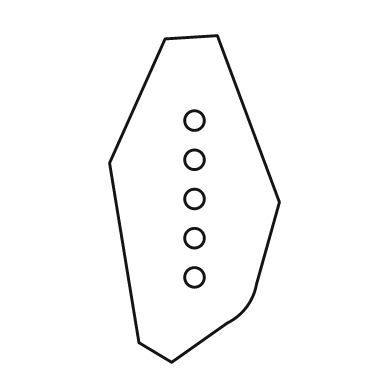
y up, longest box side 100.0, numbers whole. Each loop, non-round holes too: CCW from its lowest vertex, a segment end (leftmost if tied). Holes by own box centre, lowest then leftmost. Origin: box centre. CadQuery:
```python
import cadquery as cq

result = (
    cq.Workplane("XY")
    .moveTo(-7.0, -50.0)
    .lineTo(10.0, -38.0)
    .threePointArc((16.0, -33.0), (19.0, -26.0))
    .lineTo(26.0, -1.0)
    .lineTo(7.0, 50.0)
    .lineTo(-9.0, 49.0)
    .lineTo(-26.0, 11.0)
    .lineTo(-17.0, -44.0)
    .close()
    .moveTo(0.0, -24.0)
    .circle(3.0)
    .moveTo(0.0, -12.0)
    .circle(3.0)
    .moveTo(0.0, 0.0)
    .circle(3.0)
    .moveTo(0.0, 12.0)
    .circle(3.0)
    .moveTo(0.0, 24.0)
    .circle(3.0)
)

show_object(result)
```